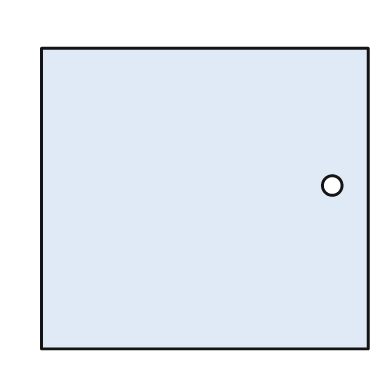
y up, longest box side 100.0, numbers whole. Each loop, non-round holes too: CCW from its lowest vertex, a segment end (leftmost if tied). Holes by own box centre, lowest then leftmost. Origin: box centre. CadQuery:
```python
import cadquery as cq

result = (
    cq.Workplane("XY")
    .moveTo(-50.0, -46.0)
    .lineTo(50.0, -46.0)
    .lineTo(50.0, 46.0)
    .lineTo(-50.0, 46.0)
    .close()
    .moveTo(39.0, 4.0)
    .circle(3.0)
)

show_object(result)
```